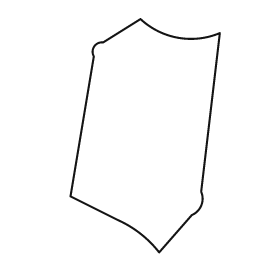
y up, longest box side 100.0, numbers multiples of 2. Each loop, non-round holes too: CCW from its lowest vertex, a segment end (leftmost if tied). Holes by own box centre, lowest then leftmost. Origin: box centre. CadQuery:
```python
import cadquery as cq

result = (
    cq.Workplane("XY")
    .moveTo(6.0, -50.0)
    .lineTo(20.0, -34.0)
    .threePointArc((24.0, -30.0), (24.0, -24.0))
    .lineTo(32.0, 44.0)
    .threePointArc((14.0, 42.0), (-2.0, 50.0))
    .lineTo(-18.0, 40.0)
    .threePointArc((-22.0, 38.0), (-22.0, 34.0))
    .lineTo(-32.0, -26.0)
    .lineTo(-12.0, -36.0)
    .threePointArc((-2.0, -42.0), (6.0, -50.0))
    .close()
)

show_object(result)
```